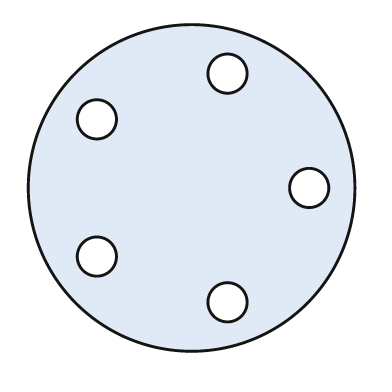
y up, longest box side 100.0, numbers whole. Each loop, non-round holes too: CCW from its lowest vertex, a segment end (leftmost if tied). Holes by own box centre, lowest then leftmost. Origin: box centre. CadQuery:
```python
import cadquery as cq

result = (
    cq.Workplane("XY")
    .moveTo(0.0, 0.0)
    .circle(50.0)
    .moveTo(11.0, -35.0)
    .circle(6.0)
    .moveTo(-29.0, -21.0)
    .circle(6.0)
    .moveTo(36.0, 0.0)
    .circle(6.0)
    .moveTo(-29.0, 21.0)
    .circle(6.0)
    .moveTo(11.0, 35.0)
    .circle(6.0)
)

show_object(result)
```